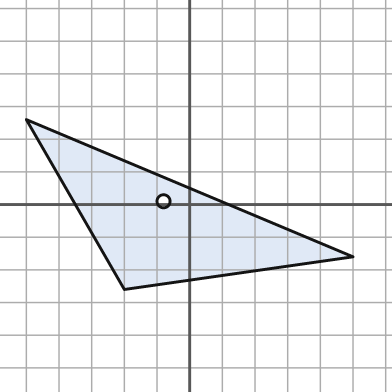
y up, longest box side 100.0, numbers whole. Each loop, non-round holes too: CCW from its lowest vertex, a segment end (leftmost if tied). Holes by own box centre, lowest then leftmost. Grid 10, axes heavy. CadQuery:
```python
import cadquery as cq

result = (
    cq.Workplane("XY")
    .moveTo(-20.0, -26.0)
    .lineTo(50.0, -16.0)
    .lineTo(-50.0, 26.0)
    .close()
    .moveTo(-8.0, 1.0)
    .circle(2.0)
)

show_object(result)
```